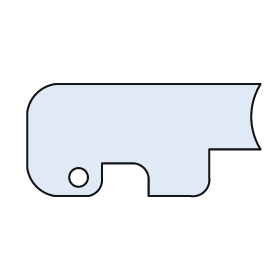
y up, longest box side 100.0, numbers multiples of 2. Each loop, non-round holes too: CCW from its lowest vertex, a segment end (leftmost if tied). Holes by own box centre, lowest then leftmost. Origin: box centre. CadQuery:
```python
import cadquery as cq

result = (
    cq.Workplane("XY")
    .moveTo(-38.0, -24.0)
    .lineTo(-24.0, -24.0)
    .threePointArc((-20.0, -22.0), (-18.0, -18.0))
    .lineTo(-18.0, -10.0)
    .lineTo(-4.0, -10.0)
    .threePointArc((0.0, -12.0), (2.0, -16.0))
    .lineTo(2.0, -24.0)
    .lineTo(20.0, -24.0)
    .threePointArc((26.0, -22.0), (28.0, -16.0))
    .lineTo(28.0, -4.0)
    .lineTo(50.0, -4.0)
    .threePointArc((46.0, 10.0), (50.0, 24.0))
    .lineTo(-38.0, 24.0)
    .threePointArc((-46.0, 20.0), (-50.0, 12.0))
    .lineTo(-50.0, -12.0)
    .threePointArc((-46.0, -20.0), (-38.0, -24.0))
    .close()
    .moveTo(-28.0, -16.0)
    .circle(4.0)
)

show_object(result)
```